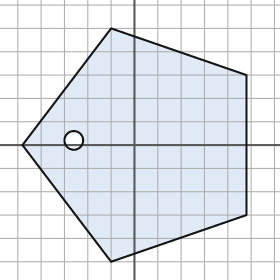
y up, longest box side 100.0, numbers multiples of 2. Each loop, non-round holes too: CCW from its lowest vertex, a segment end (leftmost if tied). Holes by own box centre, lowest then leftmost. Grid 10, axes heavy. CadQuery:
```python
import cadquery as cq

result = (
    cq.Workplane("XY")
    .moveTo(-10.0, -50.0)
    .lineTo(48.0, -30.0)
    .lineTo(48.0, 30.0)
    .lineTo(-10.0, 50.0)
    .lineTo(-48.0, 0.0)
    .close()
    .moveTo(-26.0, 2.0)
    .circle(4.0)
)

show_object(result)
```